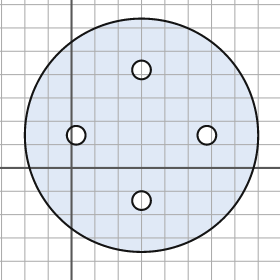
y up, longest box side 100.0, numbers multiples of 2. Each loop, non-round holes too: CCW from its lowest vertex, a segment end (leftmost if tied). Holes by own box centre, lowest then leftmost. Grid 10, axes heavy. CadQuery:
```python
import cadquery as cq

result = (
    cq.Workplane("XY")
    .moveTo(30.0, 14.0)
    .circle(50.0)
    .moveTo(30.0, -14.0)
    .circle(4.0)
    .moveTo(2.0, 14.0)
    .circle(4.0)
    .moveTo(58.0, 14.0)
    .circle(4.0)
    .moveTo(30.0, 42.0)
    .circle(4.0)
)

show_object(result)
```